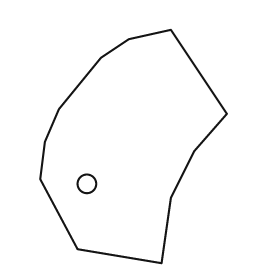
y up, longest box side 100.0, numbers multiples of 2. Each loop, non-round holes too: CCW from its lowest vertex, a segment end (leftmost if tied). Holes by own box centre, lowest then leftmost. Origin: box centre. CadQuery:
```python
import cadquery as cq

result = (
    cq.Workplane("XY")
    .moveTo(12.0, -50.0)
    .lineTo(16.0, -22.0)
    .lineTo(26.0, -2.0)
    .lineTo(40.0, 14.0)
    .lineTo(16.0, 50.0)
    .lineTo(-2.0, 46.0)
    .lineTo(-14.0, 38.0)
    .lineTo(-32.0, 16.0)
    .lineTo(-38.0, 2.0)
    .lineTo(-40.0, -14.0)
    .lineTo(-24.0, -44.0)
    .close()
    .moveTo(-20.0, -16.0)
    .circle(4.0)
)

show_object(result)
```